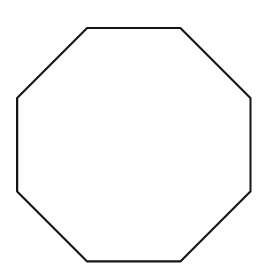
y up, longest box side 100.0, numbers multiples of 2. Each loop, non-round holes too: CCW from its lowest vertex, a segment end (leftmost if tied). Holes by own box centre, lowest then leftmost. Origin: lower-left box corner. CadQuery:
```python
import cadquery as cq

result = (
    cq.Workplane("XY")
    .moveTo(30.0, 0.0)
    .lineTo(70.0, 0.0)
    .lineTo(100.0, 30.0)
    .lineTo(100.0, 70.0)
    .lineTo(70.0, 100.0)
    .lineTo(30.0, 100.0)
    .lineTo(0.0, 70.0)
    .lineTo(0.0, 30.0)
    .close()
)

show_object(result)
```